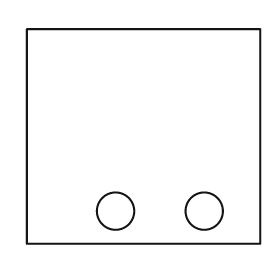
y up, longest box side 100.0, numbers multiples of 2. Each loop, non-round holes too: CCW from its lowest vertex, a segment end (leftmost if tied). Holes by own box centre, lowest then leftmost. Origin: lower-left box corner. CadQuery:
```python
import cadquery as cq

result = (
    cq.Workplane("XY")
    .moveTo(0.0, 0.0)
    .lineTo(100.0, 0.0)
    .lineTo(100.0, 92.0)
    .lineTo(0.0, 92.0)
    .close()
    .moveTo(38.0, 14.0)
    .circle(8.0)
    .moveTo(76.0, 14.0)
    .circle(8.0)
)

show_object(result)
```